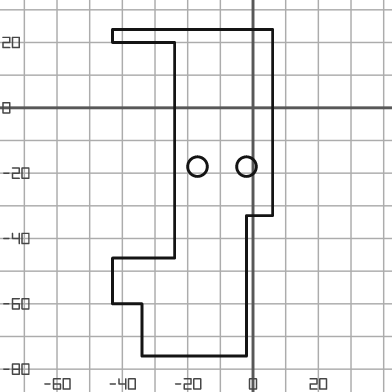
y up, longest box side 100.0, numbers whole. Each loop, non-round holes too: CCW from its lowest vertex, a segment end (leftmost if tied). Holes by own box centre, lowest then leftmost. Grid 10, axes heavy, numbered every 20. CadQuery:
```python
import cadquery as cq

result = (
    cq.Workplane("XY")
    .moveTo(-34.0, -76.0)
    .lineTo(-2.0, -76.0)
    .lineTo(-2.0, -33.0)
    .lineTo(6.0, -33.0)
    .lineTo(6.0, 24.0)
    .lineTo(-43.0, 24.0)
    .lineTo(-43.0, 20.0)
    .lineTo(-24.0, 20.0)
    .lineTo(-24.0, -46.0)
    .lineTo(-43.0, -46.0)
    .lineTo(-43.0, -60.0)
    .lineTo(-34.0, -60.0)
    .close()
    .moveTo(-17.0, -18.0)
    .circle(3.0)
    .moveTo(-2.0, -18.0)
    .circle(3.0)
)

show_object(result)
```